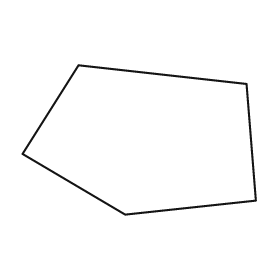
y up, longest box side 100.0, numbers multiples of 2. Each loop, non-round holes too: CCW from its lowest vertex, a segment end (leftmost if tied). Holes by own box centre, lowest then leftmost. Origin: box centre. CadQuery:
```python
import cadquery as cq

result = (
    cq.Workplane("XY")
    .moveTo(-6.0, -32.0)
    .lineTo(50.0, -26.0)
    .lineTo(46.0, 24.0)
    .lineTo(-26.0, 32.0)
    .lineTo(-50.0, -6.0)
    .close()
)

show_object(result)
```